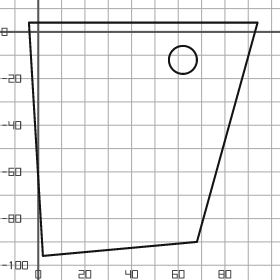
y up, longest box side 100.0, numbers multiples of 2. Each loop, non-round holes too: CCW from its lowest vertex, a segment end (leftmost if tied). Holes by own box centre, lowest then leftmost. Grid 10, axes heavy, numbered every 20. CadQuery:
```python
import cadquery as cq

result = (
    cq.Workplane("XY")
    .moveTo(2.0, -96.0)
    .lineTo(68.0, -90.0)
    .lineTo(94.0, 4.0)
    .lineTo(-4.0, 4.0)
    .close()
    .moveTo(62.0, -12.0)
    .circle(6.0)
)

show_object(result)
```